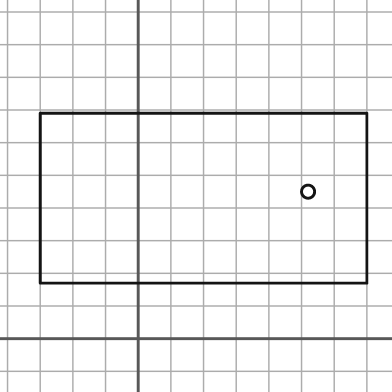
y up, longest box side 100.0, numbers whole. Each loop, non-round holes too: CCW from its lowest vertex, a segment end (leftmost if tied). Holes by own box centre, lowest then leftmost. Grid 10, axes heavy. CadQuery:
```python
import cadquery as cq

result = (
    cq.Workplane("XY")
    .moveTo(-30.0, 17.0)
    .lineTo(70.0, 17.0)
    .lineTo(70.0, 69.0)
    .lineTo(-30.0, 69.0)
    .close()
    .moveTo(52.0, 45.0)
    .circle(2.0)
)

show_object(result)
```